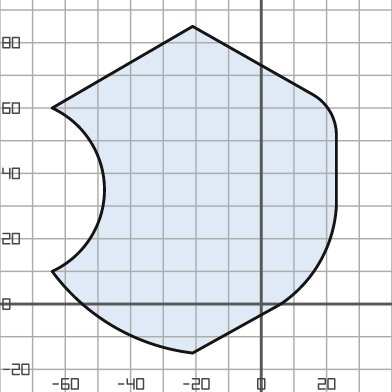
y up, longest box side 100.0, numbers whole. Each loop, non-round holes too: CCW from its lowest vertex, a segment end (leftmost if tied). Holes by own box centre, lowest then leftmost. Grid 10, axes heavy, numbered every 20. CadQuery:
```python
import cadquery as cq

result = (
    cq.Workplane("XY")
    .moveTo(-21.0, -15.0)
    .lineTo(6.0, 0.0)
    .threePointArc((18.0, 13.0), (23.0, 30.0))
    .lineTo(23.0, 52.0)
    .threePointArc((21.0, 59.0), (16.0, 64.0))
    .lineTo(-21.0, 85.0)
    .lineTo(-64.0, 60.0)
    .threePointArc((-48.0, 35.0), (-64.0, 10.0))
    .threePointArc((-45.0, -7.0), (-21.0, -15.0))
    .close()
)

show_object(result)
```